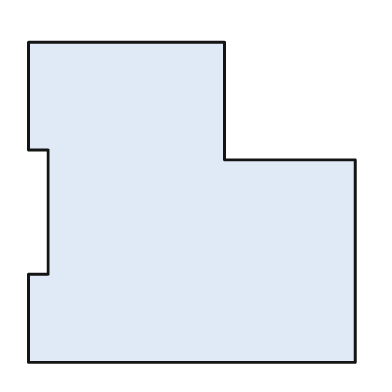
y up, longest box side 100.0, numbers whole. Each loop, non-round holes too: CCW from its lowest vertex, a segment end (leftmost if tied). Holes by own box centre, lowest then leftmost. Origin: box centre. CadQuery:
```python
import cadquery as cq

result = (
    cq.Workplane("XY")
    .moveTo(-50.0, -49.0)
    .lineTo(50.0, -49.0)
    .lineTo(50.0, 13.0)
    .lineTo(10.0, 13.0)
    .lineTo(10.0, 49.0)
    .lineTo(-50.0, 49.0)
    .lineTo(-50.0, 16.0)
    .lineTo(-44.0, 16.0)
    .lineTo(-44.0, -22.0)
    .lineTo(-50.0, -22.0)
    .close()
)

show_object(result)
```